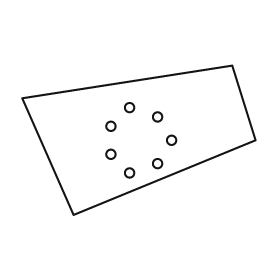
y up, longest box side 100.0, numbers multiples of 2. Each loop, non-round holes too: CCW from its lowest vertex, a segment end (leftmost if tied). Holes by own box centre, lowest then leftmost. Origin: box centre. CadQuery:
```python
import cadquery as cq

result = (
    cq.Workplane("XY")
    .moveTo(-28.0, -32.0)
    .lineTo(50.0, 0.0)
    .lineTo(40.0, 32.0)
    .lineTo(-50.0, 18.0)
    .close()
    .moveTo(-4.0, -14.0)
    .circle(2.0)
    .moveTo(8.0, -10.0)
    .circle(2.0)
    .moveTo(-12.0, -6.0)
    .circle(2.0)
    .moveTo(14.0, 0.0)
    .circle(2.0)
    .moveTo(-12.0, 6.0)
    .circle(2.0)
    .moveTo(8.0, 10.0)
    .circle(2.0)
    .moveTo(-4.0, 14.0)
    .circle(2.0)
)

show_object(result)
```